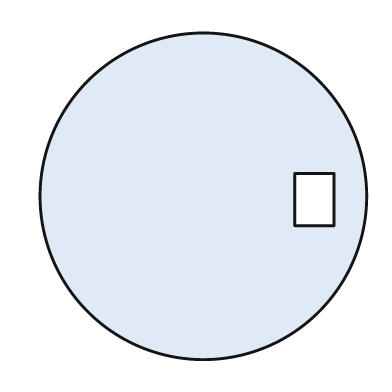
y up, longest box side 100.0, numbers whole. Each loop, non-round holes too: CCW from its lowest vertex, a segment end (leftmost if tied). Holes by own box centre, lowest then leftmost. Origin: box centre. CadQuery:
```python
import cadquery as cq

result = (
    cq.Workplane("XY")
    .moveTo(0.0, 0.0)
    .circle(50.0)
    .moveTo(28.0, -9.0)
    .lineTo(40.0, -9.0)
    .lineTo(40.0, 7.0)
    .lineTo(28.0, 7.0)
    .close()
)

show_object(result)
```